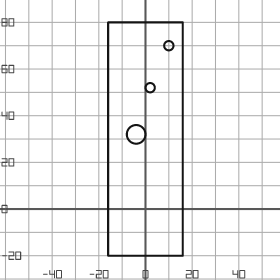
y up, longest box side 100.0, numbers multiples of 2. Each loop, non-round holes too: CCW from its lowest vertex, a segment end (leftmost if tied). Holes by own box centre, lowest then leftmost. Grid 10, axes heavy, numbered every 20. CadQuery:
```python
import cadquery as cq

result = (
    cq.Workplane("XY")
    .moveTo(-16.0, -20.0)
    .lineTo(16.0, -20.0)
    .lineTo(16.0, 80.0)
    .lineTo(-16.0, 80.0)
    .close()
    .moveTo(-4.0, 32.0)
    .circle(4.0)
    .moveTo(2.0, 52.0)
    .circle(2.0)
    .moveTo(10.0, 70.0)
    .circle(2.0)
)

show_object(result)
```